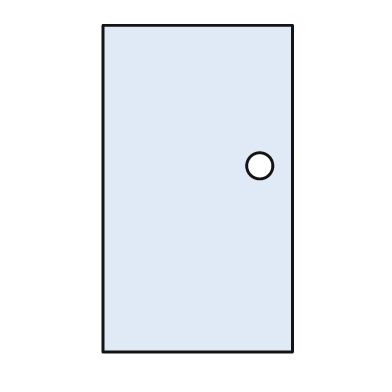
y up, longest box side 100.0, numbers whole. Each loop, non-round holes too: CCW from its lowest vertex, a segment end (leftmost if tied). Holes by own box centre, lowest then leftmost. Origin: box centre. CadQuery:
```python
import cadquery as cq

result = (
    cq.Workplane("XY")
    .moveTo(-29.0, -50.0)
    .lineTo(29.0, -50.0)
    .lineTo(29.0, 50.0)
    .lineTo(-29.0, 50.0)
    .close()
    .moveTo(19.0, 7.0)
    .circle(4.0)
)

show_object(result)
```